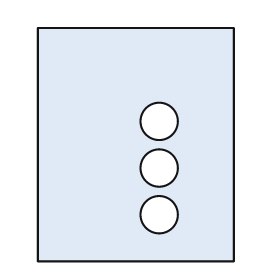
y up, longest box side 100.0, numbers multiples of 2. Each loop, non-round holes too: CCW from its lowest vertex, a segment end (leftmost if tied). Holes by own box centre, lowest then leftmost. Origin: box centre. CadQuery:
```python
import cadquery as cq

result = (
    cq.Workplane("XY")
    .moveTo(-42.0, -50.0)
    .lineTo(42.0, -50.0)
    .lineTo(42.0, 50.0)
    .lineTo(-42.0, 50.0)
    .close()
    .moveTo(10.0, -30.0)
    .circle(8.0)
    .moveTo(10.0, -10.0)
    .circle(8.0)
    .moveTo(10.0, 10.0)
    .circle(8.0)
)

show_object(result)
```